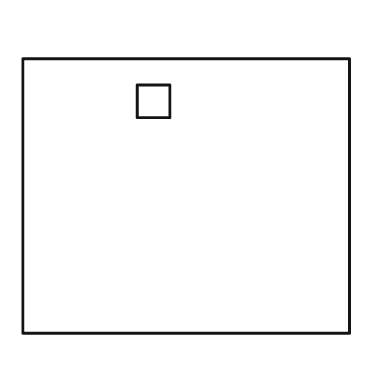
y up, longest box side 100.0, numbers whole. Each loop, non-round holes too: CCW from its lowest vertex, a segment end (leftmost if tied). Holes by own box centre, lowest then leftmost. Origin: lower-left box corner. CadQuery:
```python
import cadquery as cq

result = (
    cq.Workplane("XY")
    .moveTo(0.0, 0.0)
    .lineTo(100.0, 0.0)
    .lineTo(100.0, 84.0)
    .lineTo(0.0, 84.0)
    .close()
    .moveTo(35.0, 66.0)
    .lineTo(45.0, 66.0)
    .lineTo(45.0, 76.0)
    .lineTo(35.0, 76.0)
    .close()
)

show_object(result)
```